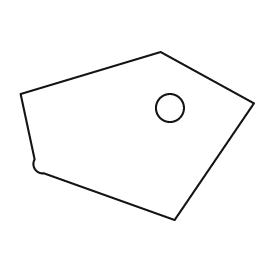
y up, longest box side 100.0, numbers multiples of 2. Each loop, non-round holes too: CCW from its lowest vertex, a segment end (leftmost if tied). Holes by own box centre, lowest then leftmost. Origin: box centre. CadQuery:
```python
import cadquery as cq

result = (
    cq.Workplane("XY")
    .moveTo(16.0, -36.0)
    .lineTo(50.0, 14.0)
    .lineTo(10.0, 36.0)
    .lineTo(-50.0, 18.0)
    .lineTo(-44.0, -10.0)
    .threePointArc((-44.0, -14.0), (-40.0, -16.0))
    .close()
    .moveTo(14.0, 12.0)
    .circle(6.0)
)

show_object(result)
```